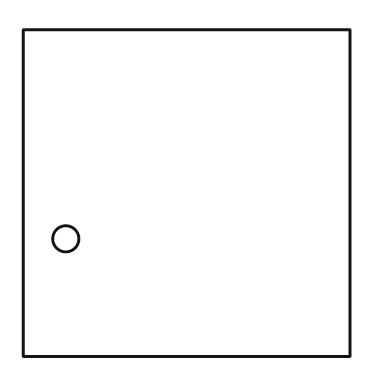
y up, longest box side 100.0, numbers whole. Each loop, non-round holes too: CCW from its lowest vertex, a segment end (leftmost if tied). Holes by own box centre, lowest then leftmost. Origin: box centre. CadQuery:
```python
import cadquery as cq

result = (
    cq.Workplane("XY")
    .moveTo(-50.0, -50.0)
    .lineTo(50.0, -50.0)
    .lineTo(50.0, 50.0)
    .lineTo(-50.0, 50.0)
    .close()
    .moveTo(-37.0, -14.0)
    .circle(4.0)
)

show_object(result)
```